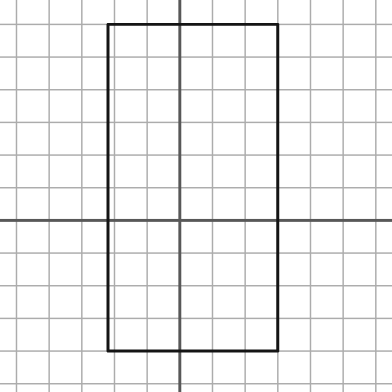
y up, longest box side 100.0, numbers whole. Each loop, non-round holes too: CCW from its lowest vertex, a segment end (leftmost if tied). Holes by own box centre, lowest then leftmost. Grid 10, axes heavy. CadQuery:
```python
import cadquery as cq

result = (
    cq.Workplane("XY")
    .moveTo(-22.0, -40.0)
    .lineTo(30.0, -40.0)
    .lineTo(30.0, 60.0)
    .lineTo(-22.0, 60.0)
    .close()
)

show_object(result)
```